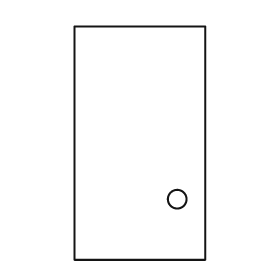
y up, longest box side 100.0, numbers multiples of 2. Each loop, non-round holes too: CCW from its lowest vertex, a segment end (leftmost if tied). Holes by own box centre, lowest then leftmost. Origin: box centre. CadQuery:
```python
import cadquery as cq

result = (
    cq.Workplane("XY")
    .moveTo(-28.0, -50.0)
    .lineTo(28.0, -50.0)
    .lineTo(28.0, 50.0)
    .lineTo(-28.0, 50.0)
    .close()
    .moveTo(16.0, -24.0)
    .circle(4.0)
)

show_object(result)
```